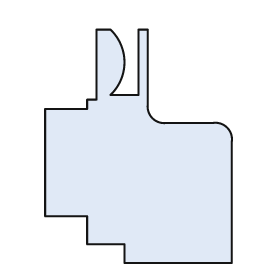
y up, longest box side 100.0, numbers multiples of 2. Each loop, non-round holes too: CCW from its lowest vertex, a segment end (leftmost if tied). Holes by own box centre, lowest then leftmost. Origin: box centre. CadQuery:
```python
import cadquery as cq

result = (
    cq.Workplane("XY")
    .moveTo(-6.0, -50.0)
    .lineTo(40.0, -50.0)
    .lineTo(40.0, 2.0)
    .threePointArc((38.0, 8.0), (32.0, 10.0))
    .lineTo(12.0, 10.0)
    .threePointArc((6.0, 12.0), (4.0, 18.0))
    .lineTo(4.0, 50.0)
    .lineTo(0.0, 50.0)
    .lineTo(0.0, 22.0)
    .lineTo(-12.0, 22.0)
    .threePointArc((-6.0, 36.0), (-12.0, 50.0))
    .lineTo(-18.0, 50.0)
    .lineTo(-18.0, 20.0)
    .lineTo(-22.0, 20.0)
    .lineTo(-22.0, 16.0)
    .lineTo(-40.0, 16.0)
    .lineTo(-40.0, -30.0)
    .lineTo(-22.0, -30.0)
    .lineTo(-22.0, -42.0)
    .lineTo(-6.0, -42.0)
    .close()
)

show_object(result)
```